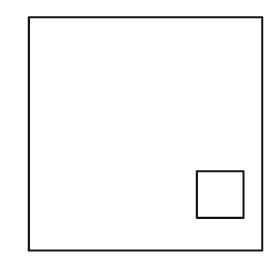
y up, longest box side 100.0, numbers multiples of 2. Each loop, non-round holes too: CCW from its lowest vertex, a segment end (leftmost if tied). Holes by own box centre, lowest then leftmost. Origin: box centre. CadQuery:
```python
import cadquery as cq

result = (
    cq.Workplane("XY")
    .moveTo(-50.0, -50.0)
    .lineTo(50.0, -50.0)
    .lineTo(50.0, 50.0)
    .lineTo(-50.0, 50.0)
    .close()
    .moveTo(22.0, -36.0)
    .lineTo(42.0, -36.0)
    .lineTo(42.0, -16.0)
    .lineTo(22.0, -16.0)
    .close()
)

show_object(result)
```